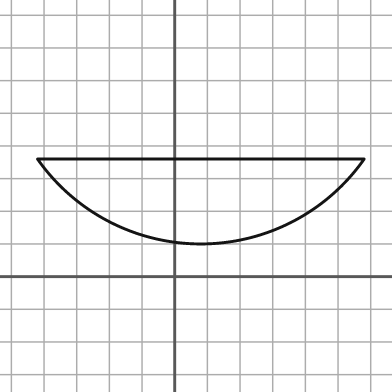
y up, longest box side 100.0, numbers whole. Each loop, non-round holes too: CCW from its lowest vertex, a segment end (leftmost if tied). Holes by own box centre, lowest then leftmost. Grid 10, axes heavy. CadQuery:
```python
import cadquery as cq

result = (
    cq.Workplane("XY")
    .moveTo(-42.0, 36.0)
    .threePointArc((8.0, 10.0), (58.0, 36.0))
    .close()
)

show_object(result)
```